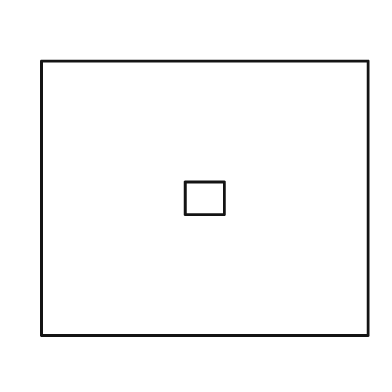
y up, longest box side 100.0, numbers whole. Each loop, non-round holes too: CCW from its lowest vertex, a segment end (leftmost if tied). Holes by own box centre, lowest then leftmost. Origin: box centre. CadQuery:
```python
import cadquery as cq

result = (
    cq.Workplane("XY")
    .moveTo(-50.0, -42.0)
    .lineTo(50.0, -42.0)
    .lineTo(50.0, 42.0)
    .lineTo(-50.0, 42.0)
    .close()
    .moveTo(-6.0, -5.0)
    .lineTo(6.0, -5.0)
    .lineTo(6.0, 5.0)
    .lineTo(-6.0, 5.0)
    .close()
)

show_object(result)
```